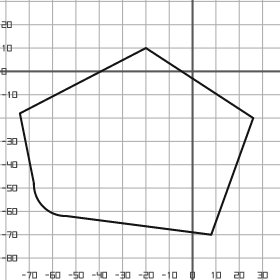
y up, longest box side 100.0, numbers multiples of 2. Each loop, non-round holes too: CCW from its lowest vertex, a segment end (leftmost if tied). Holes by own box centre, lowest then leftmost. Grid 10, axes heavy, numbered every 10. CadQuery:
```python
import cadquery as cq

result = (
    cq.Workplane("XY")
    .moveTo(8.0, -70.0)
    .lineTo(26.0, -20.0)
    .lineTo(-20.0, 10.0)
    .lineTo(-74.0, -18.0)
    .lineTo(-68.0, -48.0)
    .threePointArc((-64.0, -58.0), (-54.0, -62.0))
    .close()
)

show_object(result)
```